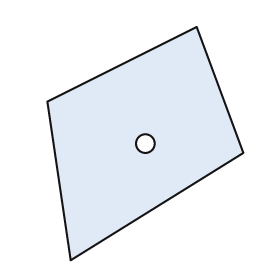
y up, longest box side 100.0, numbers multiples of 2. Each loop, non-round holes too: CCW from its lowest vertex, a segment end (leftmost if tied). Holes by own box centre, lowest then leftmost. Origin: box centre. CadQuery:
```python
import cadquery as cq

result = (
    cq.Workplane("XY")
    .moveTo(-32.0, -50.0)
    .lineTo(42.0, -4.0)
    .lineTo(22.0, 50.0)
    .lineTo(-42.0, 18.0)
    .close()
    .moveTo(0.0, 0.0)
    .circle(4.0)
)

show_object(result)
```